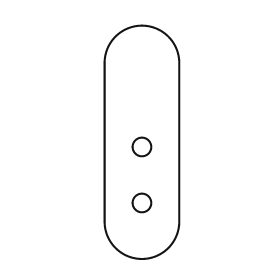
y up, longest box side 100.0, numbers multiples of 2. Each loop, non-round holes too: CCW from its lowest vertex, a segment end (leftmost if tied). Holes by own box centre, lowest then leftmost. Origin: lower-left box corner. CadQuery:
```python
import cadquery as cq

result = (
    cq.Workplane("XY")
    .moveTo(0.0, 16.0)
    .threePointArc((16.0, 0.0), (32.0, 16.0))
    .lineTo(32.0, 84.0)
    .threePointArc((16.0, 100.0), (0.0, 84.0))
    .close()
    .moveTo(16.0, 24.0)
    .circle(4.0)
    .moveTo(16.0, 48.0)
    .circle(4.0)
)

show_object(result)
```